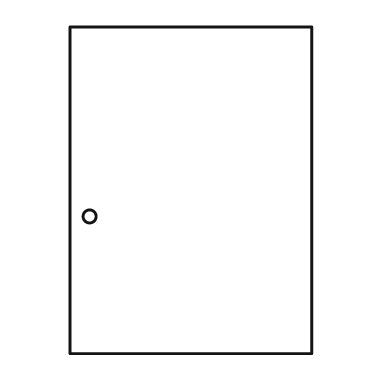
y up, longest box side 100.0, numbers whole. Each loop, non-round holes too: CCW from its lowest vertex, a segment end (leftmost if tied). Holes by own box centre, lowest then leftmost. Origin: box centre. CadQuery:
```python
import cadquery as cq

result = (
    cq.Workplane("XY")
    .moveTo(-37.0, -50.0)
    .lineTo(37.0, -50.0)
    .lineTo(37.0, 50.0)
    .lineTo(-37.0, 50.0)
    .close()
    .moveTo(-31.0, -8.0)
    .circle(2.0)
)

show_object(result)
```